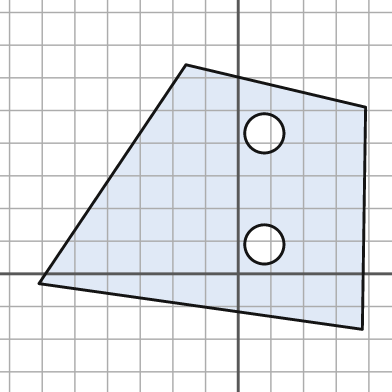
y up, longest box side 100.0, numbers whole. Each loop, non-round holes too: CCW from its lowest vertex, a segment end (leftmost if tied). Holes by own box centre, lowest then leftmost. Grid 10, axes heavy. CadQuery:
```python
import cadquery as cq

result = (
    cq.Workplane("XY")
    .moveTo(38.0, -17.0)
    .lineTo(39.0, 51.0)
    .lineTo(-16.0, 64.0)
    .lineTo(-61.0, -3.0)
    .close()
    .moveTo(8.0, 9.0)
    .circle(6.0)
    .moveTo(8.0, 43.0)
    .circle(6.0)
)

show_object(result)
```